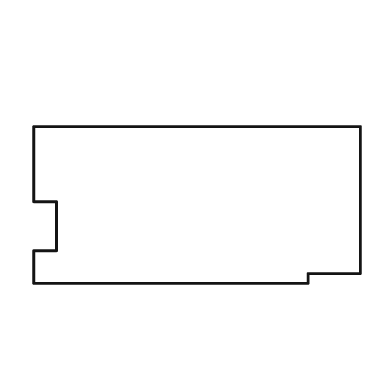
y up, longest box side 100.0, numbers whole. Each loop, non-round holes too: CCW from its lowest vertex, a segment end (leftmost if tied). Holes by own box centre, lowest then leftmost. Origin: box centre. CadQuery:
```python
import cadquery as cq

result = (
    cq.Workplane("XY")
    .moveTo(-50.0, -24.0)
    .lineTo(34.0, -24.0)
    .lineTo(34.0, -21.0)
    .lineTo(50.0, -21.0)
    .lineTo(50.0, 24.0)
    .lineTo(-50.0, 24.0)
    .lineTo(-50.0, 1.0)
    .lineTo(-43.0, 1.0)
    .lineTo(-43.0, -14.0)
    .lineTo(-50.0, -14.0)
    .close()
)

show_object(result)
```